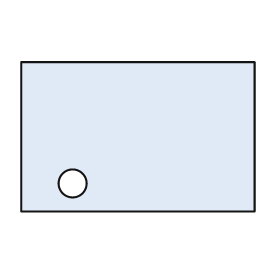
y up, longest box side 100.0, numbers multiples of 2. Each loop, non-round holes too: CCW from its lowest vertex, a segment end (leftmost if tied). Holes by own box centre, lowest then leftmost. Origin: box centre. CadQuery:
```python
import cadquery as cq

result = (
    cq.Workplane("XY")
    .moveTo(-50.0, -32.0)
    .lineTo(50.0, -32.0)
    .lineTo(50.0, 32.0)
    .lineTo(-50.0, 32.0)
    .close()
    .moveTo(-28.0, -20.0)
    .circle(6.0)
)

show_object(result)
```